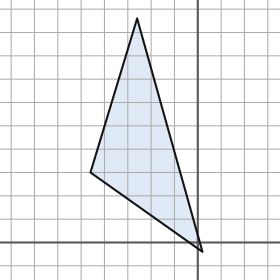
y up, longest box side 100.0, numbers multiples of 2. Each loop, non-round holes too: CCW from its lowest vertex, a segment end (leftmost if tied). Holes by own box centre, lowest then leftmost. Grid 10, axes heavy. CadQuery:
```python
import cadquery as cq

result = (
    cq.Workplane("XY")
    .moveTo(2.0, -4.0)
    .lineTo(-26.0, 96.0)
    .lineTo(-46.0, 30.0)
    .close()
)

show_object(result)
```